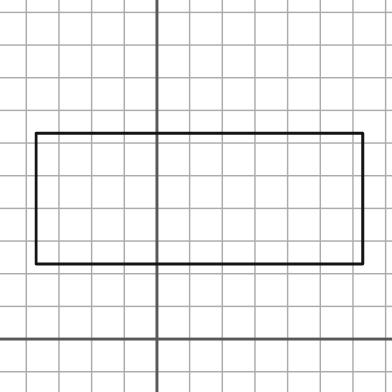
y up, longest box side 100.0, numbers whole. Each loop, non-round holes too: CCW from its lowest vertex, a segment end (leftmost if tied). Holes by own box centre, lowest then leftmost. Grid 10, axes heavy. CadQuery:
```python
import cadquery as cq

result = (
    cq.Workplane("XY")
    .moveTo(-37.0, 23.0)
    .lineTo(63.0, 23.0)
    .lineTo(63.0, 63.0)
    .lineTo(-37.0, 63.0)
    .close()
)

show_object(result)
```